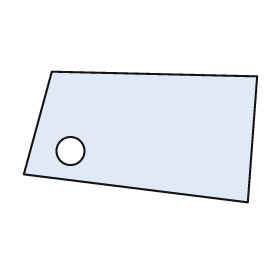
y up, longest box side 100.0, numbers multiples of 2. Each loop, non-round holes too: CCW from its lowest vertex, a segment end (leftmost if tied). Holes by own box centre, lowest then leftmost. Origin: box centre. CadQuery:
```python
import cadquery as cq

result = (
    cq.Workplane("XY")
    .moveTo(46.0, -28.0)
    .lineTo(50.0, 26.0)
    .lineTo(-38.0, 28.0)
    .lineTo(-50.0, -16.0)
    .close()
    .moveTo(-30.0, -6.0)
    .circle(6.0)
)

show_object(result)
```